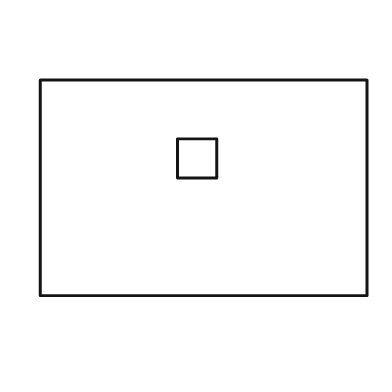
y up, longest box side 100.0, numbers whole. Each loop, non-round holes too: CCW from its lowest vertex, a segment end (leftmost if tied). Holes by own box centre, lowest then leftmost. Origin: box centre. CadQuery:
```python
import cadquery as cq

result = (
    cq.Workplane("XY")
    .moveTo(-50.0, -33.0)
    .lineTo(50.0, -33.0)
    .lineTo(50.0, 33.0)
    .lineTo(-50.0, 33.0)
    .close()
    .moveTo(-8.0, 3.0)
    .lineTo(4.0, 3.0)
    .lineTo(4.0, 15.0)
    .lineTo(-8.0, 15.0)
    .close()
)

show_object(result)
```